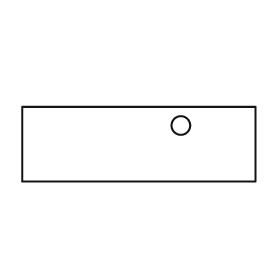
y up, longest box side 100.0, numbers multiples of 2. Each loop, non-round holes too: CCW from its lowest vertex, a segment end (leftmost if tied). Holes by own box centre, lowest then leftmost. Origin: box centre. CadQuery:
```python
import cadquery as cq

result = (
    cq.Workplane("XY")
    .moveTo(-50.0, -16.0)
    .lineTo(50.0, -16.0)
    .lineTo(50.0, 16.0)
    .lineTo(-50.0, 16.0)
    .close()
    .moveTo(18.0, 8.0)
    .circle(4.0)
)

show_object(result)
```